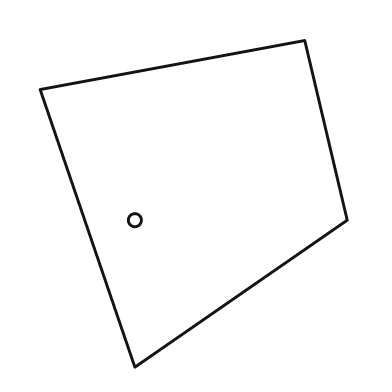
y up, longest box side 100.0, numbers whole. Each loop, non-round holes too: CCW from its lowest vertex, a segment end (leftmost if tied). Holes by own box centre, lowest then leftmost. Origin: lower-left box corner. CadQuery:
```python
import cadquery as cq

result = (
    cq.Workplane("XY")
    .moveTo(29.0, 0.0)
    .lineTo(94.0, 45.0)
    .lineTo(81.0, 100.0)
    .lineTo(0.0, 85.0)
    .close()
    .moveTo(29.0, 45.0)
    .circle(2.0)
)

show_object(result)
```